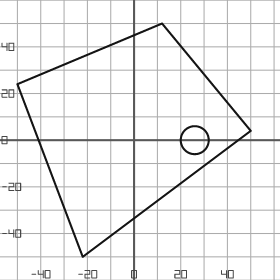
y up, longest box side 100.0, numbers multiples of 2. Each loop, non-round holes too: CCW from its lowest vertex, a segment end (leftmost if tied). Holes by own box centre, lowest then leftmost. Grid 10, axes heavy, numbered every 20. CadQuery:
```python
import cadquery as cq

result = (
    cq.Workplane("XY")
    .moveTo(-22.0, -50.0)
    .lineTo(50.0, 4.0)
    .lineTo(12.0, 50.0)
    .lineTo(-50.0, 24.0)
    .close()
    .moveTo(26.0, 0.0)
    .circle(6.0)
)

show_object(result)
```